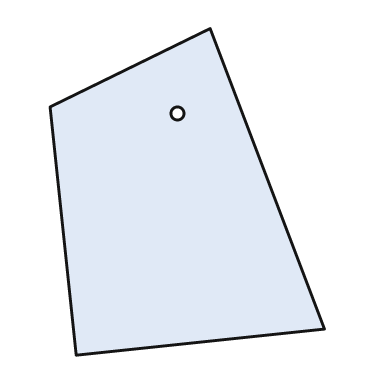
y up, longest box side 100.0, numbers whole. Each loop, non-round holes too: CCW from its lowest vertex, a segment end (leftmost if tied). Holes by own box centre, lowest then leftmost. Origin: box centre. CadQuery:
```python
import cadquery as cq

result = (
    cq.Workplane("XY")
    .moveTo(-34.0, -50.0)
    .lineTo(42.0, -42.0)
    .lineTo(7.0, 50.0)
    .lineTo(-42.0, 26.0)
    .close()
    .moveTo(-3.0, 24.0)
    .circle(2.0)
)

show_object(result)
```